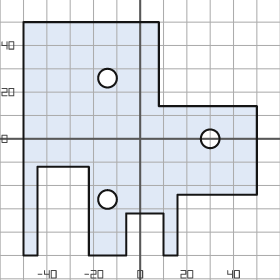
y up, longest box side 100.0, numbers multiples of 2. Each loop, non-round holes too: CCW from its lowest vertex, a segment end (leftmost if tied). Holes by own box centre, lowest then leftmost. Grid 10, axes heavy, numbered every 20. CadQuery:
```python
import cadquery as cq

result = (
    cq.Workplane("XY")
    .moveTo(-50.0, -50.0)
    .lineTo(-44.0, -50.0)
    .lineTo(-44.0, -12.0)
    .lineTo(-22.0, -12.0)
    .lineTo(-22.0, -50.0)
    .lineTo(-6.0, -50.0)
    .lineTo(-6.0, -32.0)
    .lineTo(10.0, -32.0)
    .lineTo(10.0, -50.0)
    .lineTo(16.0, -50.0)
    .lineTo(16.0, -24.0)
    .lineTo(50.0, -24.0)
    .lineTo(50.0, 14.0)
    .lineTo(8.0, 14.0)
    .lineTo(8.0, 50.0)
    .lineTo(-50.0, 50.0)
    .close()
    .moveTo(-14.0, -26.0)
    .circle(4.0)
    .moveTo(30.0, 0.0)
    .circle(4.0)
    .moveTo(-14.0, 26.0)
    .circle(4.0)
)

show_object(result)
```